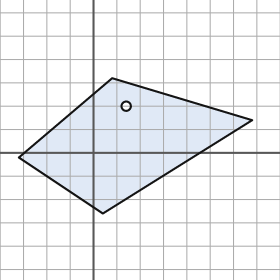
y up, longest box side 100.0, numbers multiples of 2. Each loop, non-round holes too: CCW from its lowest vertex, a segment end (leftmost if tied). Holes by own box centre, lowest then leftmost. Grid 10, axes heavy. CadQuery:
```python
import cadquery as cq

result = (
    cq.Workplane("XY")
    .moveTo(4.0, -26.0)
    .lineTo(68.0, 14.0)
    .lineTo(8.0, 32.0)
    .lineTo(-32.0, -2.0)
    .close()
    .moveTo(14.0, 20.0)
    .circle(2.0)
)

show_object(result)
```